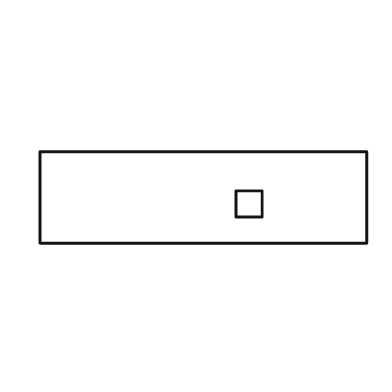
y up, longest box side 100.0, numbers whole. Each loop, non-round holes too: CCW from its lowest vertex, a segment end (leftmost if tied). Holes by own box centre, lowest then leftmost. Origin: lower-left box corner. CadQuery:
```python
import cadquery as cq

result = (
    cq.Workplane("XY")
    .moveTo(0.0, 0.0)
    .lineTo(100.0, 0.0)
    .lineTo(100.0, 28.0)
    .lineTo(0.0, 28.0)
    .close()
    .moveTo(60.0, 8.0)
    .lineTo(68.0, 8.0)
    .lineTo(68.0, 16.0)
    .lineTo(60.0, 16.0)
    .close()
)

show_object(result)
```